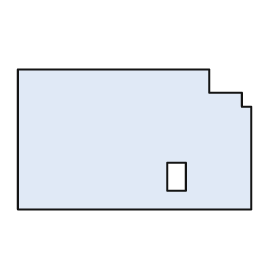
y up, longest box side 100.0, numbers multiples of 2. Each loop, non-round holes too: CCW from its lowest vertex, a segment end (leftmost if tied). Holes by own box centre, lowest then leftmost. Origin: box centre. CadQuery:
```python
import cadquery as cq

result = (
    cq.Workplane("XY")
    .moveTo(-50.0, -30.0)
    .lineTo(50.0, -30.0)
    .lineTo(50.0, 14.0)
    .lineTo(46.0, 14.0)
    .lineTo(46.0, 20.0)
    .lineTo(32.0, 20.0)
    .lineTo(32.0, 30.0)
    .lineTo(-50.0, 30.0)
    .close()
    .moveTo(14.0, -22.0)
    .lineTo(22.0, -22.0)
    .lineTo(22.0, -10.0)
    .lineTo(14.0, -10.0)
    .close()
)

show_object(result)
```